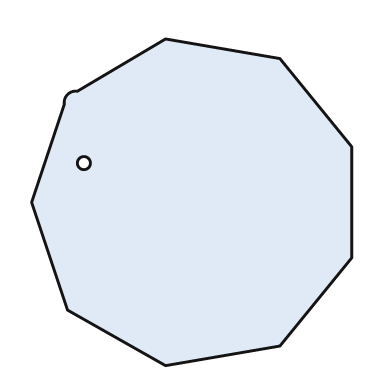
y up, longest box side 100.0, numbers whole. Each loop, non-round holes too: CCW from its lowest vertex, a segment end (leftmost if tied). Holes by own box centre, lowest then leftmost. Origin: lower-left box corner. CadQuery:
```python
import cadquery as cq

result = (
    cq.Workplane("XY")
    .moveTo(41.0, 0.0)
    .lineTo(76.0, 6.0)
    .lineTo(98.0, 33.0)
    .lineTo(98.0, 67.0)
    .lineTo(76.0, 94.0)
    .lineTo(41.0, 100.0)
    .lineTo(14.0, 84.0)
    .threePointArc((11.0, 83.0), (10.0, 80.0))
    .lineTo(0.0, 50.0)
    .lineTo(11.0, 17.0)
    .close()
    .moveTo(16.0, 62.0)
    .circle(2.0)
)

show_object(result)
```